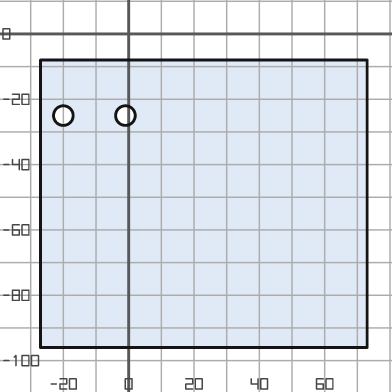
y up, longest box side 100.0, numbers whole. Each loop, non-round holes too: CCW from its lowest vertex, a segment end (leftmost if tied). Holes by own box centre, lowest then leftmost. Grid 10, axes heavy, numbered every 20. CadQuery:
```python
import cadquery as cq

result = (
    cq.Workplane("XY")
    .moveTo(-27.0, -96.0)
    .lineTo(73.0, -96.0)
    .lineTo(73.0, -8.0)
    .lineTo(-27.0, -8.0)
    .close()
    .moveTo(-20.0, -25.0)
    .circle(3.0)
    .moveTo(-1.0, -25.0)
    .circle(3.0)
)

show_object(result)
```